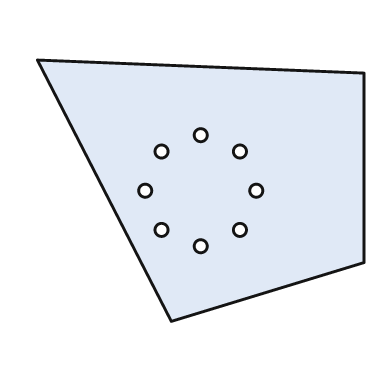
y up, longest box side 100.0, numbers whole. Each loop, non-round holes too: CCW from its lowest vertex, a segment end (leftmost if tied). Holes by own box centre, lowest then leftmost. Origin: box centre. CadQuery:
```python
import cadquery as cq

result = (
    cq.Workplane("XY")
    .moveTo(-9.0, -40.0)
    .lineTo(50.0, -22.0)
    .lineTo(50.0, 36.0)
    .lineTo(-50.0, 40.0)
    .close()
    .moveTo(0.0, -17.0)
    .circle(2.0)
    .moveTo(-12.0, -12.0)
    .circle(2.0)
    .moveTo(12.0, -12.0)
    .circle(2.0)
    .moveTo(-17.0, 0.0)
    .circle(2.0)
    .moveTo(17.0, 0.0)
    .circle(2.0)
    .moveTo(-12.0, 12.0)
    .circle(2.0)
    .moveTo(12.0, 12.0)
    .circle(2.0)
    .moveTo(0.0, 17.0)
    .circle(2.0)
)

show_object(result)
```